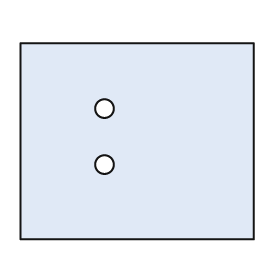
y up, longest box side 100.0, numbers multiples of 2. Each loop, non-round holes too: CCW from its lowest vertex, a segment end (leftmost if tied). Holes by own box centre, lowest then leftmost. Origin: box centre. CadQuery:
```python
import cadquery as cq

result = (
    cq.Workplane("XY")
    .moveTo(-50.0, -42.0)
    .lineTo(50.0, -42.0)
    .lineTo(50.0, 42.0)
    .lineTo(-50.0, 42.0)
    .close()
    .moveTo(-14.0, -10.0)
    .circle(4.0)
    .moveTo(-14.0, 14.0)
    .circle(4.0)
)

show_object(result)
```